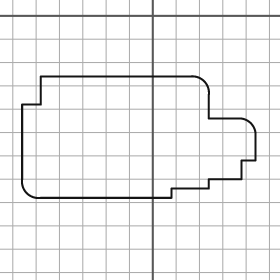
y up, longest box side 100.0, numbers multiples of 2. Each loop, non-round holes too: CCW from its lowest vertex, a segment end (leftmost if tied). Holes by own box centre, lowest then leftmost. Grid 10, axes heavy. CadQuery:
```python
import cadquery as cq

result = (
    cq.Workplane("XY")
    .moveTo(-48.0, -78.0)
    .lineTo(8.0, -78.0)
    .lineTo(8.0, -74.0)
    .lineTo(24.0, -74.0)
    .lineTo(24.0, -70.0)
    .lineTo(38.0, -70.0)
    .lineTo(38.0, -62.0)
    .lineTo(44.0, -62.0)
    .lineTo(44.0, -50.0)
    .threePointArc((42.0, -46.0), (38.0, -44.0))
    .lineTo(24.0, -44.0)
    .lineTo(24.0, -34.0)
    .threePointArc((22.0, -28.0), (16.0, -26.0))
    .lineTo(-48.0, -26.0)
    .lineTo(-48.0, -38.0)
    .lineTo(-56.0, -38.0)
    .lineTo(-56.0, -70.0)
    .threePointArc((-54.0, -76.0), (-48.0, -78.0))
    .close()
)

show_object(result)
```